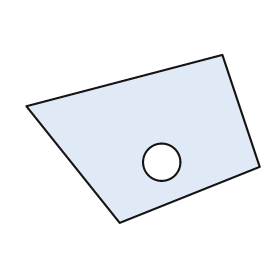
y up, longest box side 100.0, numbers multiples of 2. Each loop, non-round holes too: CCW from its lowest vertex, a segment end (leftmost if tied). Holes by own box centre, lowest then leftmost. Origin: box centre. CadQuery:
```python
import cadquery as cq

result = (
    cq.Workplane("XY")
    .moveTo(-10.0, -36.0)
    .lineTo(50.0, -12.0)
    .lineTo(34.0, 36.0)
    .lineTo(-50.0, 14.0)
    .close()
    .moveTo(8.0, -10.0)
    .circle(8.0)
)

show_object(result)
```